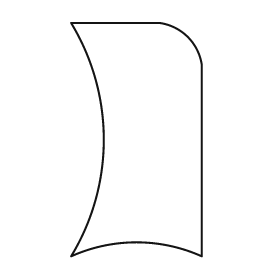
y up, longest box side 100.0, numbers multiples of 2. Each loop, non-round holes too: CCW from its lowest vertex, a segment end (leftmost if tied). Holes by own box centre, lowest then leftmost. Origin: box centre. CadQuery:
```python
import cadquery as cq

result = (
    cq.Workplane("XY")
    .moveTo(-28.0, -50.0)
    .threePointArc((0.0, -44.0), (28.0, -50.0))
    .lineTo(28.0, 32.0)
    .threePointArc((22.0, 44.0), (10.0, 50.0))
    .lineTo(-28.0, 50.0)
    .threePointArc((-14.0, 0.0), (-28.0, -50.0))
    .close()
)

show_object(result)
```